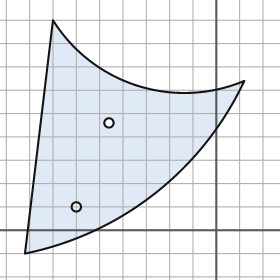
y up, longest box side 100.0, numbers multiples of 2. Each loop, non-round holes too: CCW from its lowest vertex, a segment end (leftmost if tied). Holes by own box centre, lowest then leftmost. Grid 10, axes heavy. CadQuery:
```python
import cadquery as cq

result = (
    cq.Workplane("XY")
    .moveTo(-82.0, -10.0)
    .threePointArc((-26.0, 16.0), (12.0, 64.0))
    .threePointArc((-34.0, 62.0), (-70.0, 90.0))
    .close()
    .moveTo(-60.0, 10.0)
    .circle(2.0)
    .moveTo(-46.0, 46.0)
    .circle(2.0)
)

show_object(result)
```